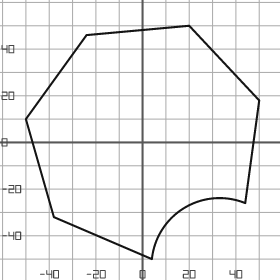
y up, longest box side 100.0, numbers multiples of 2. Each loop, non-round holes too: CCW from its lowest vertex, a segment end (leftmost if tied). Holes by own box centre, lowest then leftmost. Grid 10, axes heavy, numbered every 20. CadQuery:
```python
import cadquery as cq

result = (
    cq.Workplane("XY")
    .moveTo(4.0, -50.0)
    .threePointArc((18.0, -28.0), (44.0, -26.0))
    .lineTo(50.0, 18.0)
    .lineTo(20.0, 50.0)
    .lineTo(-24.0, 46.0)
    .lineTo(-50.0, 10.0)
    .lineTo(-38.0, -32.0)
    .close()
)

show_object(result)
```